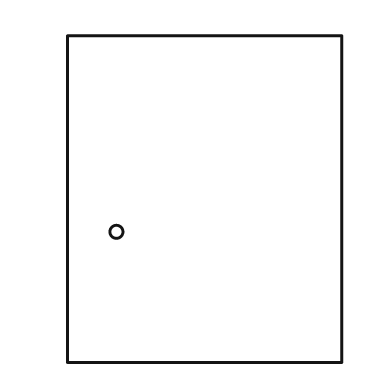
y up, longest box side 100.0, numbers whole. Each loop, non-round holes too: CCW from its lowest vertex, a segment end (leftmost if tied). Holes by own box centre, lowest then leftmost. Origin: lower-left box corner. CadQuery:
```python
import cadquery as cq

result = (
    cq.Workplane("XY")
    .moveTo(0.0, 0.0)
    .lineTo(84.0, 0.0)
    .lineTo(84.0, 100.0)
    .lineTo(0.0, 100.0)
    .close()
    .moveTo(15.0, 40.0)
    .circle(2.0)
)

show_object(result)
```